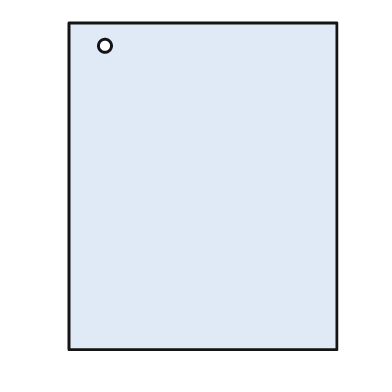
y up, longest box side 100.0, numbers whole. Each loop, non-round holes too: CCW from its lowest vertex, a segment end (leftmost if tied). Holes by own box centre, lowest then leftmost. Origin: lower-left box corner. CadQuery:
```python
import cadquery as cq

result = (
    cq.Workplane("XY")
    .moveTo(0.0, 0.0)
    .lineTo(82.0, 0.0)
    .lineTo(82.0, 100.0)
    .lineTo(0.0, 100.0)
    .close()
    .moveTo(11.0, 93.0)
    .circle(2.0)
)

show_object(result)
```